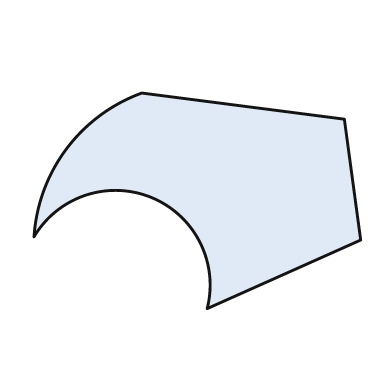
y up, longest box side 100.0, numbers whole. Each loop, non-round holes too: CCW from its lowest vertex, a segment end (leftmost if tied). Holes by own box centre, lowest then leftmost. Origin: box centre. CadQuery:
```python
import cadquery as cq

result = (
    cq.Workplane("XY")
    .moveTo(3.0, -33.0)
    .lineTo(50.0, -12.0)
    .lineTo(45.0, 25.0)
    .lineTo(-17.0, 33.0)
    .threePointArc((-40.0, 16.0), (-50.0, -11.0))
    .threePointArc((-14.0, 1.0), (3.0, -33.0))
    .close()
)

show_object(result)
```